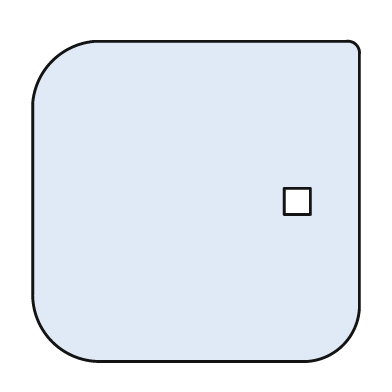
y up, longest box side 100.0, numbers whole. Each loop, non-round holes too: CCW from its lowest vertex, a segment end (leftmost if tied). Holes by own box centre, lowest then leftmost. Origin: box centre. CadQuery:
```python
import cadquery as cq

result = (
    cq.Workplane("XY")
    .moveTo(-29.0, -49.0)
    .lineTo(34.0, -49.0)
    .threePointArc((45.0, -44.0), (50.0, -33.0))
    .lineTo(50.0, 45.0)
    .threePointArc((49.0, 48.0), (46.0, 49.0))
    .lineTo(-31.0, 49.0)
    .threePointArc((-44.0, 43.0), (-50.0, 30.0))
    .lineTo(-50.0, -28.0)
    .threePointArc((-44.0, -43.0), (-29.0, -49.0))
    .close()
    .moveTo(27.0, -4.0)
    .lineTo(35.0, -4.0)
    .lineTo(35.0, 4.0)
    .lineTo(27.0, 4.0)
    .close()
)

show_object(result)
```